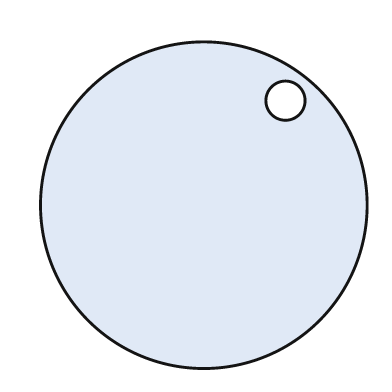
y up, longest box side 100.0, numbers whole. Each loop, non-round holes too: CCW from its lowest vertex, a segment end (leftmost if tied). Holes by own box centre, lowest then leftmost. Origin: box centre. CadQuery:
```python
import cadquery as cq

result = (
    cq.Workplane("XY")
    .moveTo(0.0, 0.0)
    .circle(50.0)
    .moveTo(25.0, 32.0)
    .circle(6.0)
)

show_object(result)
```